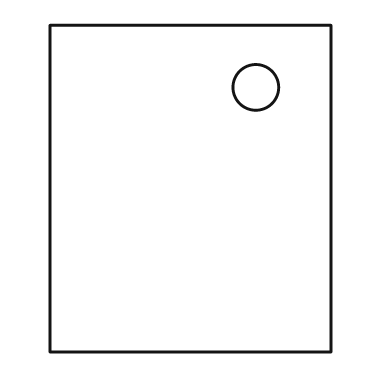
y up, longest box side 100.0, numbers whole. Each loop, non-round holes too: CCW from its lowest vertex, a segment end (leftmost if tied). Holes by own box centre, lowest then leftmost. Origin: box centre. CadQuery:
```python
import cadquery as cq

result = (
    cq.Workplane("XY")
    .moveTo(-43.0, -50.0)
    .lineTo(43.0, -50.0)
    .lineTo(43.0, 50.0)
    .lineTo(-43.0, 50.0)
    .close()
    .moveTo(20.0, 31.0)
    .circle(7.0)
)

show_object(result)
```